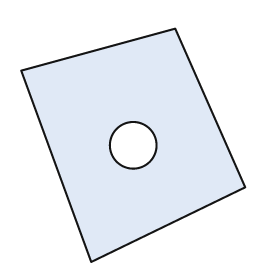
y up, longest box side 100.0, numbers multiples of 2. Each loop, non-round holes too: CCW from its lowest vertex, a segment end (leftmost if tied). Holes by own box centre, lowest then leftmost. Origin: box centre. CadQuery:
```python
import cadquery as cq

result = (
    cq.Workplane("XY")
    .moveTo(-18.0, -50.0)
    .lineTo(48.0, -18.0)
    .lineTo(18.0, 50.0)
    .lineTo(-48.0, 32.0)
    .close()
    .moveTo(0.0, 0.0)
    .circle(10.0)
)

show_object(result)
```